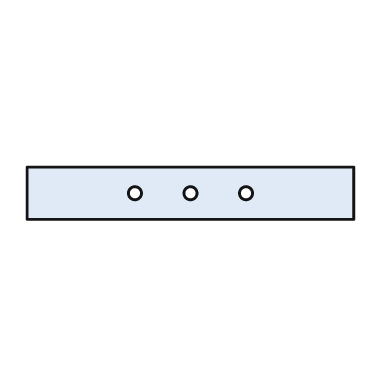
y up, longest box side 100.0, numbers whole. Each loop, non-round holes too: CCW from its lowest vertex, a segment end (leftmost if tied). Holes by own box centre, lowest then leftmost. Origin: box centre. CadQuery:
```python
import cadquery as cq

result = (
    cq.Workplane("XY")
    .moveTo(-50.0, -8.0)
    .lineTo(50.0, -8.0)
    .lineTo(50.0, 8.0)
    .lineTo(-50.0, 8.0)
    .close()
    .moveTo(-17.0, 0.0)
    .circle(2.0)
    .moveTo(0.0, 0.0)
    .circle(2.0)
    .moveTo(17.0, 0.0)
    .circle(2.0)
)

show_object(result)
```